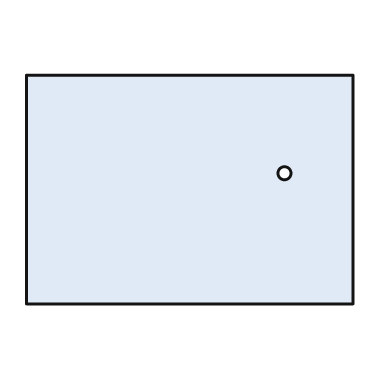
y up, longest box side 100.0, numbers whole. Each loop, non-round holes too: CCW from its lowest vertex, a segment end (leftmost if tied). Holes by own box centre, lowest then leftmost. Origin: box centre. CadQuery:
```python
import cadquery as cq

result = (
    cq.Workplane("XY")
    .moveTo(-50.0, -35.0)
    .lineTo(50.0, -35.0)
    .lineTo(50.0, 35.0)
    .lineTo(-50.0, 35.0)
    .close()
    .moveTo(29.0, 5.0)
    .circle(2.0)
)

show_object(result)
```